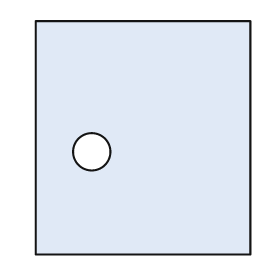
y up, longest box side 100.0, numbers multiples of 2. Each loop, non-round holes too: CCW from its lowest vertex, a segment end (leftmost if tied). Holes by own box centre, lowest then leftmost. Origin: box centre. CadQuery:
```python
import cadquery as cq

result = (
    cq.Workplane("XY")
    .moveTo(-46.0, -50.0)
    .lineTo(46.0, -50.0)
    .lineTo(46.0, 50.0)
    .lineTo(-46.0, 50.0)
    .close()
    .moveTo(-22.0, -6.0)
    .circle(8.0)
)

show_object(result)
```